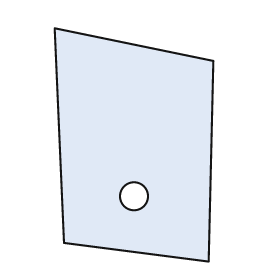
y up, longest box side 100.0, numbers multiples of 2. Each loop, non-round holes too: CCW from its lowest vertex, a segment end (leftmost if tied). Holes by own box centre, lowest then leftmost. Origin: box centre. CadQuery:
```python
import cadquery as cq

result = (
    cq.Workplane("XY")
    .moveTo(32.0, -50.0)
    .lineTo(34.0, 36.0)
    .lineTo(-34.0, 50.0)
    .lineTo(-30.0, -42.0)
    .close()
    .moveTo(0.0, -22.0)
    .circle(6.0)
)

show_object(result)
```